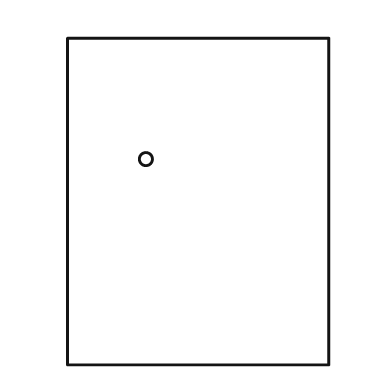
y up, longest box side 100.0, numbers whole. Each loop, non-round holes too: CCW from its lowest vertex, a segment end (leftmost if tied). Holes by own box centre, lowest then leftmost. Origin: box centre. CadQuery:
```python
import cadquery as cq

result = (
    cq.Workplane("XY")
    .moveTo(-40.0, -50.0)
    .lineTo(40.0, -50.0)
    .lineTo(40.0, 50.0)
    .lineTo(-40.0, 50.0)
    .close()
    .moveTo(-16.0, 13.0)
    .circle(2.0)
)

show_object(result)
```